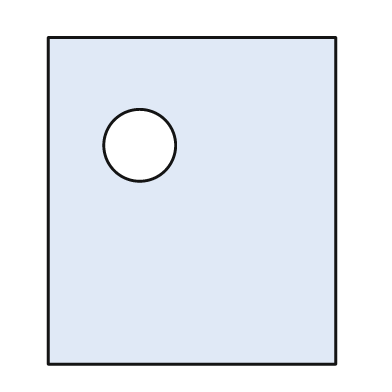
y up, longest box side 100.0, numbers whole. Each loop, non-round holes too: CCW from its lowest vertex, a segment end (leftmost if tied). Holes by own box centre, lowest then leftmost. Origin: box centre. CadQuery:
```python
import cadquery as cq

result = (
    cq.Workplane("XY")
    .moveTo(-44.0, -50.0)
    .lineTo(44.0, -50.0)
    .lineTo(44.0, 50.0)
    .lineTo(-44.0, 50.0)
    .close()
    .moveTo(-16.0, 17.0)
    .circle(11.0)
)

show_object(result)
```